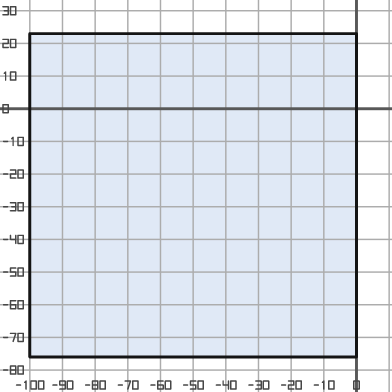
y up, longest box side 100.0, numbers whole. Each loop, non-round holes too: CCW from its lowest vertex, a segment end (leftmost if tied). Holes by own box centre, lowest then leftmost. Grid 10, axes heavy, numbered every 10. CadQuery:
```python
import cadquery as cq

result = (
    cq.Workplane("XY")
    .moveTo(-100.0, -76.0)
    .lineTo(0.0, -76.0)
    .lineTo(0.0, 23.0)
    .lineTo(-100.0, 23.0)
    .close()
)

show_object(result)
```